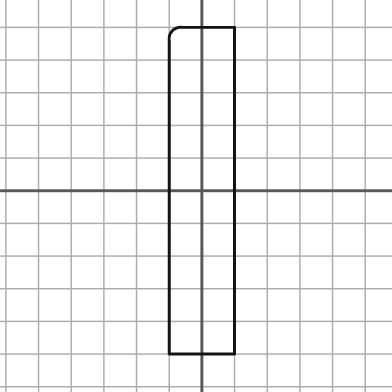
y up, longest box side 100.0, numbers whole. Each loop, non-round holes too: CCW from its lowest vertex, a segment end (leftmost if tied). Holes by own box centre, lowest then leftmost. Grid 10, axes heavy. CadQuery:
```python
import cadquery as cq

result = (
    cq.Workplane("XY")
    .moveTo(-10.0, -50.0)
    .lineTo(10.0, -50.0)
    .lineTo(10.0, 50.0)
    .lineTo(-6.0, 50.0)
    .threePointArc((-9.0, 49.0), (-10.0, 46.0))
    .close()
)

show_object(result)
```